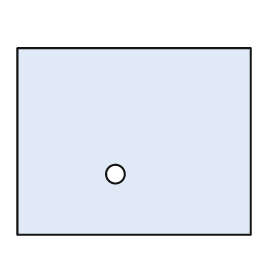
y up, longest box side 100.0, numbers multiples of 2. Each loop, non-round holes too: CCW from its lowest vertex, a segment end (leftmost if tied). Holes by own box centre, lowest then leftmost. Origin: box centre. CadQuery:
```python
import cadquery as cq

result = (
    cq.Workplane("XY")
    .moveTo(-50.0, -40.0)
    .lineTo(50.0, -40.0)
    .lineTo(50.0, 40.0)
    .lineTo(-50.0, 40.0)
    .close()
    .moveTo(-8.0, -14.0)
    .circle(4.0)
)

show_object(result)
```